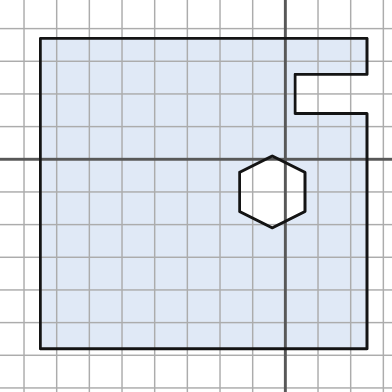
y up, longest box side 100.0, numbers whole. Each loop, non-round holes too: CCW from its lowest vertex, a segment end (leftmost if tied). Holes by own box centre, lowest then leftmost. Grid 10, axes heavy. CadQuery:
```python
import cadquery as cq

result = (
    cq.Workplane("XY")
    .moveTo(-75.0, -58.0)
    .lineTo(25.0, -58.0)
    .lineTo(25.0, 14.0)
    .lineTo(3.0, 14.0)
    .lineTo(3.0, 26.0)
    .lineTo(25.0, 26.0)
    .lineTo(25.0, 37.0)
    .lineTo(-75.0, 37.0)
    .close()
    .moveTo(-4.0, -21.0)
    .lineTo(6.0, -16.0)
    .lineTo(6.0, -4.0)
    .lineTo(-4.0, 1.0)
    .lineTo(-14.0, -4.0)
    .lineTo(-14.0, -16.0)
    .close()
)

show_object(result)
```